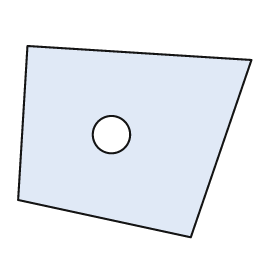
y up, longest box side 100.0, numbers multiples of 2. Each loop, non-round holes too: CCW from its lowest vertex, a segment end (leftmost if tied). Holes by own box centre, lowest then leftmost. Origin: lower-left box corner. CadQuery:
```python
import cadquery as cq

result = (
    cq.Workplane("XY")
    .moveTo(74.0, 0.0)
    .lineTo(100.0, 76.0)
    .lineTo(4.0, 82.0)
    .lineTo(0.0, 16.0)
    .close()
    .moveTo(40.0, 44.0)
    .circle(8.0)
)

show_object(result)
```